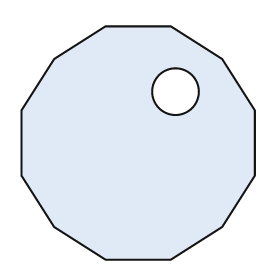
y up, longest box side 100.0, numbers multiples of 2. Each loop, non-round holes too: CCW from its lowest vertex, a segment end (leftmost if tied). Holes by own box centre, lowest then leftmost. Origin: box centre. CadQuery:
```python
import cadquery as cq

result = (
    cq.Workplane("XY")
    .moveTo(-14.0, -50.0)
    .lineTo(14.0, -50.0)
    .lineTo(36.0, -36.0)
    .lineTo(50.0, -14.0)
    .lineTo(50.0, 14.0)
    .lineTo(36.0, 36.0)
    .lineTo(14.0, 50.0)
    .lineTo(-14.0, 50.0)
    .lineTo(-36.0, 36.0)
    .lineTo(-50.0, 14.0)
    .lineTo(-50.0, -14.0)
    .lineTo(-36.0, -36.0)
    .close()
    .moveTo(16.0, 22.0)
    .circle(10.0)
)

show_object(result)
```